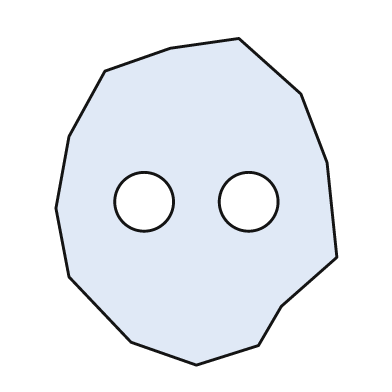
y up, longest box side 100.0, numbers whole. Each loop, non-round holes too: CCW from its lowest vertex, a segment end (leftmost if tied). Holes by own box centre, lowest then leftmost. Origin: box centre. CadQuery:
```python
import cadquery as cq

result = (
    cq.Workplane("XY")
    .moveTo(0.0, -50.0)
    .lineTo(19.0, -44.0)
    .lineTo(26.0, -32.0)
    .lineTo(43.0, -17.0)
    .lineTo(40.0, 12.0)
    .lineTo(32.0, 33.0)
    .lineTo(13.0, 50.0)
    .lineTo(-8.0, 47.0)
    .lineTo(-28.0, 40.0)
    .lineTo(-39.0, 20.0)
    .lineTo(-43.0, -2.0)
    .lineTo(-39.0, -23.0)
    .lineTo(-20.0, -43.0)
    .close()
    .moveTo(-16.0, 0.0)
    .circle(9.0)
    .moveTo(16.0, 0.0)
    .circle(9.0)
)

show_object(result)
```